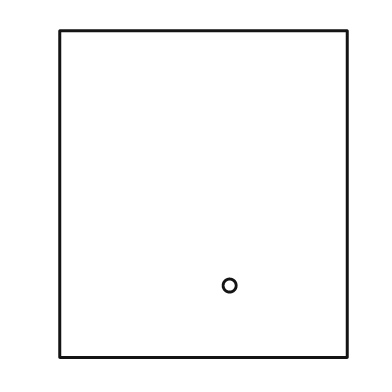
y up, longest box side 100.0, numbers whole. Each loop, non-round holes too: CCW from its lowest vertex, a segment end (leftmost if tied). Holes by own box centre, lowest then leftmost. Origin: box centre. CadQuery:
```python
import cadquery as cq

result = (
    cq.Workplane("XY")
    .moveTo(-44.0, -50.0)
    .lineTo(44.0, -50.0)
    .lineTo(44.0, 50.0)
    .lineTo(-44.0, 50.0)
    .close()
    .moveTo(8.0, -28.0)
    .circle(2.0)
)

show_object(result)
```